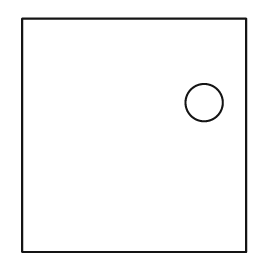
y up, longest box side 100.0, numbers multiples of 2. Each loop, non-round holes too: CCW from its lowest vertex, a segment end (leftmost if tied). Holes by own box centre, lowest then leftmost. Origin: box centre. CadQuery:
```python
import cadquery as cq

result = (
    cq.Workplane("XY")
    .moveTo(-48.0, -50.0)
    .lineTo(48.0, -50.0)
    .lineTo(48.0, 50.0)
    .lineTo(-48.0, 50.0)
    .close()
    .moveTo(30.0, 14.0)
    .circle(8.0)
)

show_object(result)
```